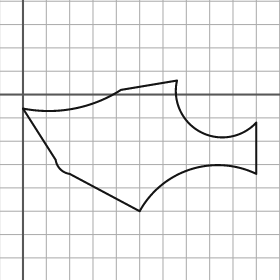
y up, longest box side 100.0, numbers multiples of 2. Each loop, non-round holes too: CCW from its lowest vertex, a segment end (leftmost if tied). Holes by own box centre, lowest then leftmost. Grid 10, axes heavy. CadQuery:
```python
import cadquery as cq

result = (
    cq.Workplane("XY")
    .moveTo(50.0, -50.0)
    .threePointArc((72.0, -32.0), (100.0, -34.0))
    .lineTo(100.0, -12.0)
    .threePointArc((76.0, -16.0), (66.0, 6.0))
    .lineTo(42.0, 2.0)
    .threePointArc((22.0, -6.0), (0.0, -6.0))
    .lineTo(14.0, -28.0)
    .threePointArc((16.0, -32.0), (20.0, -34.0))
    .close()
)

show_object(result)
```